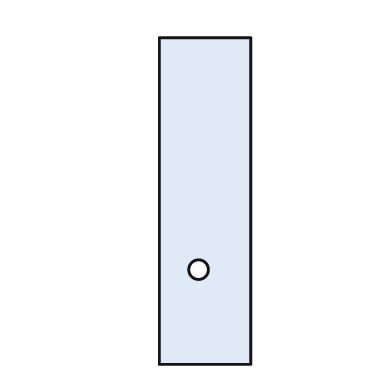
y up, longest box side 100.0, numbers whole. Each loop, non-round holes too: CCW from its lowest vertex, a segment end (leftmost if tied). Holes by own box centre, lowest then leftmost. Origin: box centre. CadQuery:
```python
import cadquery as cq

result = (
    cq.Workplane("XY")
    .moveTo(-14.0, -50.0)
    .lineTo(14.0, -50.0)
    .lineTo(14.0, 50.0)
    .lineTo(-14.0, 50.0)
    .close()
    .moveTo(-2.0, -21.0)
    .circle(3.0)
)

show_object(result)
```